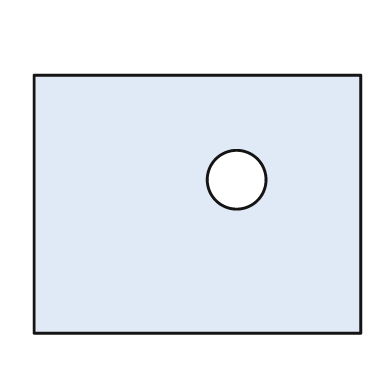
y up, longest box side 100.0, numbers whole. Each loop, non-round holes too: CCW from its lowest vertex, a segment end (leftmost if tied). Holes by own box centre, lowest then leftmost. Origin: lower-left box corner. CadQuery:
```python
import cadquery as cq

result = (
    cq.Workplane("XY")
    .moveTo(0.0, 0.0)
    .lineTo(100.0, 0.0)
    .lineTo(100.0, 79.0)
    .lineTo(0.0, 79.0)
    .close()
    .moveTo(62.0, 47.0)
    .circle(9.0)
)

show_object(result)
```